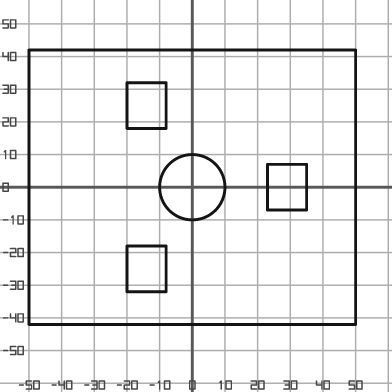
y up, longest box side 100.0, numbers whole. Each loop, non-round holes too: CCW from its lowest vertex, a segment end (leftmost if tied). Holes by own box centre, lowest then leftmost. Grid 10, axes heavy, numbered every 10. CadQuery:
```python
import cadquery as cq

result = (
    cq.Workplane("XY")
    .moveTo(-50.0, -42.0)
    .lineTo(50.0, -42.0)
    .lineTo(50.0, 42.0)
    .lineTo(-50.0, 42.0)
    .close()
    .moveTo(-20.0, -32.0)
    .lineTo(-8.0, -32.0)
    .lineTo(-8.0, -18.0)
    .lineTo(-20.0, -18.0)
    .close()
    .moveTo(0.0, 0.0)
    .circle(10.0)
    .moveTo(23.0, -7.0)
    .lineTo(35.0, -7.0)
    .lineTo(35.0, 7.0)
    .lineTo(23.0, 7.0)
    .close()
    .moveTo(-20.0, 18.0)
    .lineTo(-8.0, 18.0)
    .lineTo(-8.0, 32.0)
    .lineTo(-20.0, 32.0)
    .close()
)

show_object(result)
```